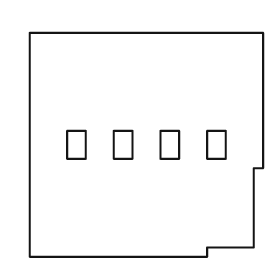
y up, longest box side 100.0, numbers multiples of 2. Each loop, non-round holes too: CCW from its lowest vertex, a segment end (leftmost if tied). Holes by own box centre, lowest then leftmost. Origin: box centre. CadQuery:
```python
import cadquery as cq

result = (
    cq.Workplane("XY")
    .moveTo(-50.0, -48.0)
    .lineTo(26.0, -48.0)
    .lineTo(26.0, -44.0)
    .lineTo(46.0, -44.0)
    .lineTo(46.0, -10.0)
    .lineTo(50.0, -10.0)
    .lineTo(50.0, 48.0)
    .lineTo(-50.0, 48.0)
    .close()
    .moveTo(-34.0, -6.0)
    .lineTo(-26.0, -6.0)
    .lineTo(-26.0, 6.0)
    .lineTo(-34.0, 6.0)
    .close()
    .moveTo(-14.0, -6.0)
    .lineTo(-6.0, -6.0)
    .lineTo(-6.0, 6.0)
    .lineTo(-14.0, 6.0)
    .close()
    .moveTo(6.0, -6.0)
    .lineTo(14.0, -6.0)
    .lineTo(14.0, 6.0)
    .lineTo(6.0, 6.0)
    .close()
    .moveTo(26.0, -6.0)
    .lineTo(34.0, -6.0)
    .lineTo(34.0, 6.0)
    .lineTo(26.0, 6.0)
    .close()
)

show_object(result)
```